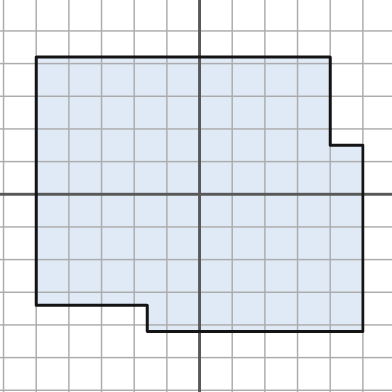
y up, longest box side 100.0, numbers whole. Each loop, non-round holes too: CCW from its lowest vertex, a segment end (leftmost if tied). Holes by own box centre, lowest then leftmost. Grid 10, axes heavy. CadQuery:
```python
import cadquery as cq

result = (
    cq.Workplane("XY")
    .moveTo(-16.0, -42.0)
    .lineTo(50.0, -42.0)
    .lineTo(50.0, 15.0)
    .lineTo(40.0, 15.0)
    .lineTo(40.0, 42.0)
    .lineTo(-50.0, 42.0)
    .lineTo(-50.0, -34.0)
    .lineTo(-16.0, -34.0)
    .close()
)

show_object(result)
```